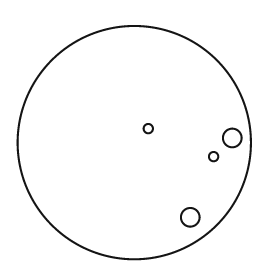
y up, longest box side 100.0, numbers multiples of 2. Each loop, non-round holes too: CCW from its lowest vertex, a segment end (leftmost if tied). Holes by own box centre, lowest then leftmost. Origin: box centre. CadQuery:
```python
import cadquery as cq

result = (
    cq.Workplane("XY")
    .moveTo(0.0, 0.0)
    .circle(50.0)
    .moveTo(24.0, -32.0)
    .circle(4.0)
    .moveTo(34.0, -6.0)
    .circle(2.0)
    .moveTo(42.0, 2.0)
    .circle(4.0)
    .moveTo(6.0, 6.0)
    .circle(2.0)
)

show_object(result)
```